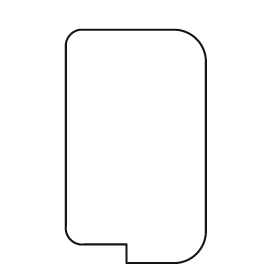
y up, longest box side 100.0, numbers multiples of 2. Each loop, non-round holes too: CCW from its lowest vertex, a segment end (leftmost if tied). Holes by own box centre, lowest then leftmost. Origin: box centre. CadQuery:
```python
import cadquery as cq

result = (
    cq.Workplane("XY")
    .moveTo(-4.0, -50.0)
    .lineTo(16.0, -50.0)
    .threePointArc((26.0, -46.0), (30.0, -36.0))
    .lineTo(30.0, 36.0)
    .threePointArc((26.0, 46.0), (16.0, 50.0))
    .lineTo(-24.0, 50.0)
    .threePointArc((-28.0, 48.0), (-30.0, 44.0))
    .lineTo(-30.0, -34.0)
    .threePointArc((-28.0, -40.0), (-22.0, -42.0))
    .lineTo(-4.0, -42.0)
    .close()
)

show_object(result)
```